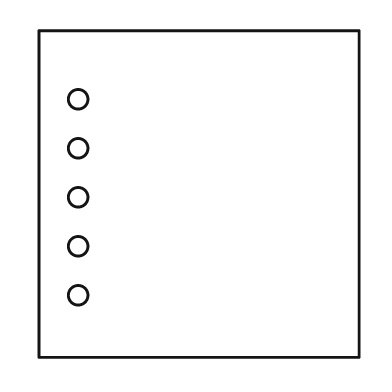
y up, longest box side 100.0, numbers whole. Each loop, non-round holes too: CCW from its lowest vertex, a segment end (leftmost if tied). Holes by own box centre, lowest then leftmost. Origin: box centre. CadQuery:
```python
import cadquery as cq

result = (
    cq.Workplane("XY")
    .moveTo(-49.0, -50.0)
    .lineTo(49.0, -50.0)
    .lineTo(49.0, 50.0)
    .lineTo(-49.0, 50.0)
    .close()
    .moveTo(-37.0, -31.0)
    .circle(3.0)
    .moveTo(-37.0, -16.0)
    .circle(3.0)
    .moveTo(-37.0, -1.0)
    .circle(3.0)
    .moveTo(-37.0, 14.0)
    .circle(3.0)
    .moveTo(-37.0, 29.0)
    .circle(3.0)
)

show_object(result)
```